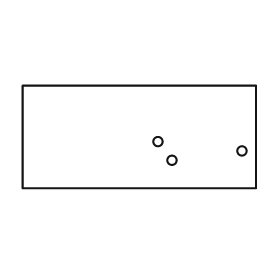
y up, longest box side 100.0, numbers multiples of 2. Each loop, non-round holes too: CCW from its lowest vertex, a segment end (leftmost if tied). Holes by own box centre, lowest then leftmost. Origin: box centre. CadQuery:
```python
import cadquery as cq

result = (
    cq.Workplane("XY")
    .moveTo(-50.0, -22.0)
    .lineTo(50.0, -22.0)
    .lineTo(50.0, 22.0)
    .lineTo(-50.0, 22.0)
    .close()
    .moveTo(14.0, -10.0)
    .circle(2.0)
    .moveTo(44.0, -6.0)
    .circle(2.0)
    .moveTo(8.0, -2.0)
    .circle(2.0)
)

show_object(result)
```